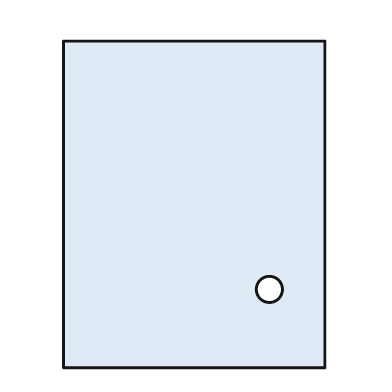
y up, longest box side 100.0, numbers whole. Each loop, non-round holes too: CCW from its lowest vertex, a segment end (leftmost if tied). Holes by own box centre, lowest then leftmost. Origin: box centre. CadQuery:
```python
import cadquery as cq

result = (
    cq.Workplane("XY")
    .moveTo(-40.0, -50.0)
    .lineTo(40.0, -50.0)
    .lineTo(40.0, 50.0)
    .lineTo(-40.0, 50.0)
    .close()
    .moveTo(23.0, -26.0)
    .circle(4.0)
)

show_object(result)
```